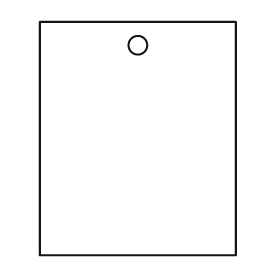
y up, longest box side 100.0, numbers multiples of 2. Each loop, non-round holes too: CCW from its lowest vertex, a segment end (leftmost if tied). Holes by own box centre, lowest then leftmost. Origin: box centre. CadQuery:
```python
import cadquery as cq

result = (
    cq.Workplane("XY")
    .moveTo(-42.0, -50.0)
    .lineTo(42.0, -50.0)
    .lineTo(42.0, 50.0)
    .lineTo(-42.0, 50.0)
    .close()
    .moveTo(0.0, 40.0)
    .circle(4.0)
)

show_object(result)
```